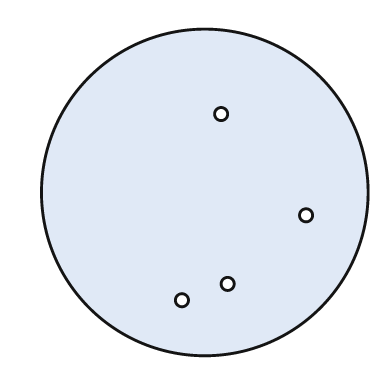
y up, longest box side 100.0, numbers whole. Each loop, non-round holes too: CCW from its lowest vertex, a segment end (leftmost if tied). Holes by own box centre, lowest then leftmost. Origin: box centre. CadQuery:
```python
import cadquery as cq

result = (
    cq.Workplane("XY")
    .moveTo(0.0, 0.0)
    .circle(50.0)
    .moveTo(-7.0, -33.0)
    .circle(2.0)
    .moveTo(7.0, -28.0)
    .circle(2.0)
    .moveTo(31.0, -7.0)
    .circle(2.0)
    .moveTo(5.0, 24.0)
    .circle(2.0)
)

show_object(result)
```